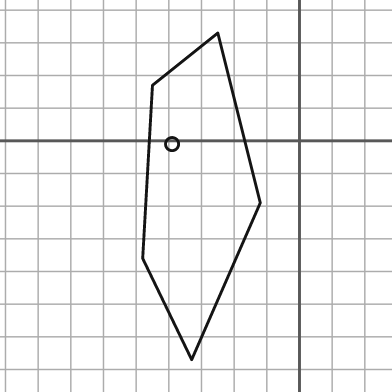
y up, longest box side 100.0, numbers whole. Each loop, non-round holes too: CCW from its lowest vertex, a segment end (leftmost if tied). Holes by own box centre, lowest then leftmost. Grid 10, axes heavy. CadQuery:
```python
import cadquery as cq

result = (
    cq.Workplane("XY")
    .moveTo(-33.0, -67.0)
    .lineTo(-12.0, -19.0)
    .lineTo(-25.0, 33.0)
    .lineTo(-45.0, 17.0)
    .lineTo(-48.0, -36.0)
    .close()
    .moveTo(-39.0, -1.0)
    .circle(2.0)
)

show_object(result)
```